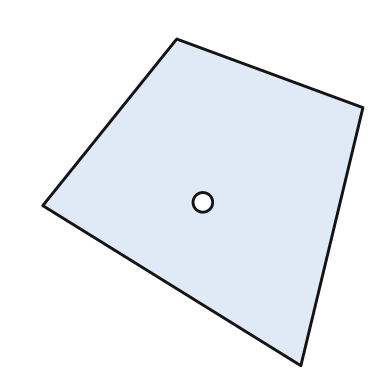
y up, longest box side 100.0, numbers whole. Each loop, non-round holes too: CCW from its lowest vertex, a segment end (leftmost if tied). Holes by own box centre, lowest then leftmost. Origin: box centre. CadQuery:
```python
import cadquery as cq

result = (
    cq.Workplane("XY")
    .moveTo(30.0, -50.0)
    .lineTo(49.0, 29.0)
    .lineTo(-8.0, 50.0)
    .lineTo(-49.0, -1.0)
    .close()
    .moveTo(0.0, 0.0)
    .circle(3.0)
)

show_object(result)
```